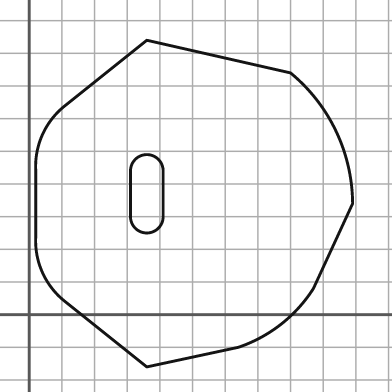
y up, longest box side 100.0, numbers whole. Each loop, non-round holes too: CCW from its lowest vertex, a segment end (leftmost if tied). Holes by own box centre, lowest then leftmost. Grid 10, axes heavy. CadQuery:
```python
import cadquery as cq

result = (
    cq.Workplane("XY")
    .moveTo(36.0, -16.0)
    .lineTo(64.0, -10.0)
    .threePointArc((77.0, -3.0), (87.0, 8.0))
    .lineTo(99.0, 34.0)
    .threePointArc((94.0, 56.0), (80.0, 74.0))
    .lineTo(36.0, 84.0)
    .lineTo(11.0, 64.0)
    .threePointArc((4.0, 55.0), (2.0, 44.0))
    .lineTo(2.0, 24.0)
    .threePointArc((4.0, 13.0), (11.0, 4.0))
    .close()
    .moveTo(31.0, 30.0)
    .threePointArc((36.0, 25.0), (41.0, 30.0))
    .lineTo(41.0, 44.0)
    .threePointArc((36.0, 49.0), (31.0, 44.0))
    .close()
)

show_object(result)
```